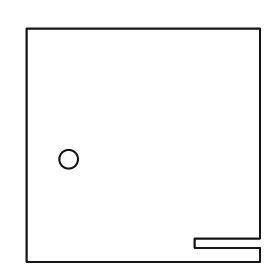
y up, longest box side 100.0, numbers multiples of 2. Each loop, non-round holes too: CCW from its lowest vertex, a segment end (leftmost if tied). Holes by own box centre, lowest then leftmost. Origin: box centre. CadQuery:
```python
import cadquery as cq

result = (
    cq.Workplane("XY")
    .moveTo(-50.0, -50.0)
    .lineTo(50.0, -50.0)
    .lineTo(50.0, -44.0)
    .lineTo(22.0, -44.0)
    .lineTo(22.0, -40.0)
    .lineTo(50.0, -40.0)
    .lineTo(50.0, 50.0)
    .lineTo(-50.0, 50.0)
    .close()
    .moveTo(-32.0, -6.0)
    .circle(4.0)
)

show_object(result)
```